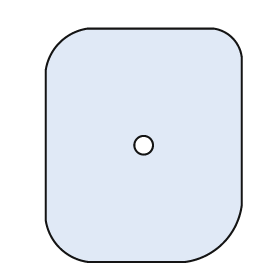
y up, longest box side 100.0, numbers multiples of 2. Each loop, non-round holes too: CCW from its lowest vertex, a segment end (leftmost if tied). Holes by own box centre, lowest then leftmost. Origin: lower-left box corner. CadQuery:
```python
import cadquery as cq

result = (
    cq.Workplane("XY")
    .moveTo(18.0, 0.0)
    .lineTo(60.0, 0.0)
    .threePointArc((76.0, 8.0), (84.0, 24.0))
    .lineTo(84.0, 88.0)
    .threePointArc((80.0, 96.0), (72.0, 100.0))
    .lineTo(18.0, 100.0)
    .threePointArc((6.0, 94.0), (0.0, 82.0))
    .lineTo(0.0, 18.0)
    .threePointArc((6.0, 6.0), (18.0, 0.0))
    .close()
    .moveTo(42.0, 50.0)
    .circle(4.0)
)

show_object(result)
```